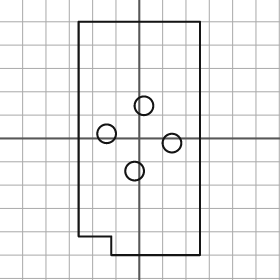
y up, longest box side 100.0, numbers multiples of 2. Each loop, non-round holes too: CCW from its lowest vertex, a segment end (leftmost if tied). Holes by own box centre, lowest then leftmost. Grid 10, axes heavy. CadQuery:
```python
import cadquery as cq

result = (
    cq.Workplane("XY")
    .moveTo(-12.0, -50.0)
    .lineTo(26.0, -50.0)
    .lineTo(26.0, 50.0)
    .lineTo(-26.0, 50.0)
    .lineTo(-26.0, -42.0)
    .lineTo(-12.0, -42.0)
    .close()
    .moveTo(-2.0, -14.0)
    .circle(4.0)
    .moveTo(14.0, -2.0)
    .circle(4.0)
    .moveTo(-14.0, 2.0)
    .circle(4.0)
    .moveTo(2.0, 14.0)
    .circle(4.0)
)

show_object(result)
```